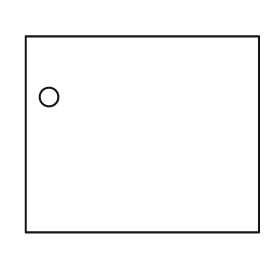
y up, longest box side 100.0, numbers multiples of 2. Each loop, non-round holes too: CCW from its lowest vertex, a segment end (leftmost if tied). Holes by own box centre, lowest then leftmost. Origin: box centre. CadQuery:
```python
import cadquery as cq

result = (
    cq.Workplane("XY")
    .moveTo(-50.0, -42.0)
    .lineTo(50.0, -42.0)
    .lineTo(50.0, 42.0)
    .lineTo(-50.0, 42.0)
    .close()
    .moveTo(-40.0, 16.0)
    .circle(4.0)
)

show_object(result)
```